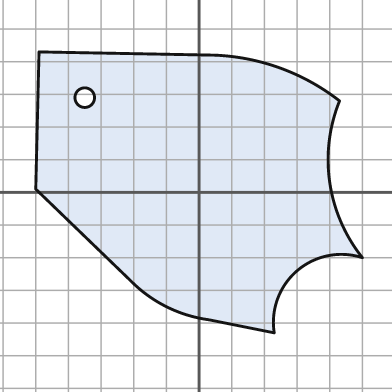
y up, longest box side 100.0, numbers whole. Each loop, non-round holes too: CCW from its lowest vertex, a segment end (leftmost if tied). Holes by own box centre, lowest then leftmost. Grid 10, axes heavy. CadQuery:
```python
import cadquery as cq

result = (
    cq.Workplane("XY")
    .moveTo(23.0, -43.0)
    .threePointArc((30.0, -24.0), (50.0, -20.0))
    .threePointArc((40.0, 3.0), (43.0, 28.0))
    .threePointArc((25.0, 38.0), (5.0, 42.0))
    .lineTo(-49.0, 43.0)
    .lineTo(-50.0, 1.0)
    .lineTo(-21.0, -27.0)
    .threePointArc((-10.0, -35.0), (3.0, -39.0))
    .close()
    .moveTo(-35.0, 29.0)
    .circle(3.0)
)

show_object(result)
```